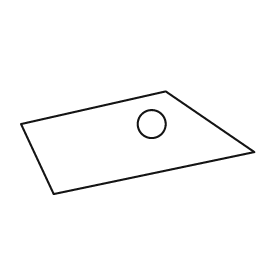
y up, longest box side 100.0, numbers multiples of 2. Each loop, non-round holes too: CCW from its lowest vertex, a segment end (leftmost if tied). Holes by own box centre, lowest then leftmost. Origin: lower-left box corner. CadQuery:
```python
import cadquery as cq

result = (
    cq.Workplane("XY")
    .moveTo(14.0, 0.0)
    .lineTo(100.0, 18.0)
    .lineTo(62.0, 44.0)
    .lineTo(0.0, 30.0)
    .close()
    .moveTo(56.0, 30.0)
    .circle(6.0)
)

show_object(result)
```